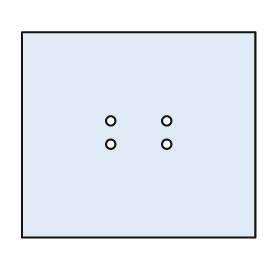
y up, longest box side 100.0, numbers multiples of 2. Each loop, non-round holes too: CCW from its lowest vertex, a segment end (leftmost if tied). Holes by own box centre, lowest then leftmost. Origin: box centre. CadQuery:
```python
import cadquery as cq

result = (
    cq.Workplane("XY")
    .moveTo(-50.0, -44.0)
    .lineTo(50.0, -44.0)
    .lineTo(50.0, 44.0)
    .lineTo(-50.0, 44.0)
    .close()
    .moveTo(-12.0, -4.0)
    .circle(2.0)
    .moveTo(12.0, -4.0)
    .circle(2.0)
    .moveTo(-12.0, 6.0)
    .circle(2.0)
    .moveTo(12.0, 6.0)
    .circle(2.0)
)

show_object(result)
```